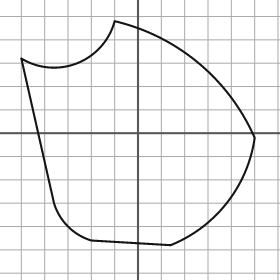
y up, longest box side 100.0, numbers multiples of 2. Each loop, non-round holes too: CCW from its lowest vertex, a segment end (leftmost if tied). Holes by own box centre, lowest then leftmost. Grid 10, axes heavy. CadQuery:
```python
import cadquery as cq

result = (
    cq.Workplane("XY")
    .moveTo(14.0, -48.0)
    .threePointArc((38.0, -30.0), (50.0, -2.0))
    .threePointArc((26.0, 30.0), (-10.0, 48.0))
    .threePointArc((-26.0, 30.0), (-50.0, 32.0))
    .lineTo(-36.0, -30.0)
    .threePointArc((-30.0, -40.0), (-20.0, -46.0))
    .close()
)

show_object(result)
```